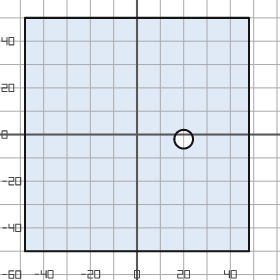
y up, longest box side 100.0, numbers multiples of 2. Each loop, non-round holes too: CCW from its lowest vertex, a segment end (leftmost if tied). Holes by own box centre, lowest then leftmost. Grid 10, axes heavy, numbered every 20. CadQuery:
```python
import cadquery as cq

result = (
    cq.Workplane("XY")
    .moveTo(-48.0, -50.0)
    .lineTo(48.0, -50.0)
    .lineTo(48.0, 50.0)
    .lineTo(-48.0, 50.0)
    .close()
    .moveTo(20.0, -2.0)
    .circle(4.0)
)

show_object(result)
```